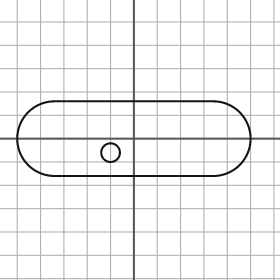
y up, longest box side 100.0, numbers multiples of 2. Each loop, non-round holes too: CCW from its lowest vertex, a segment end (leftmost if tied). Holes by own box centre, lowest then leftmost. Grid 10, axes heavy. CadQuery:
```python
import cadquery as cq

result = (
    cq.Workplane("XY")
    .moveTo(-34.0, -16.0)
    .lineTo(34.0, -16.0)
    .threePointArc((50.0, 0.0), (34.0, 16.0))
    .lineTo(-34.0, 16.0)
    .threePointArc((-50.0, 0.0), (-34.0, -16.0))
    .close()
    .moveTo(-10.0, -6.0)
    .circle(4.0)
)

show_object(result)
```